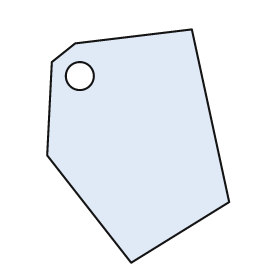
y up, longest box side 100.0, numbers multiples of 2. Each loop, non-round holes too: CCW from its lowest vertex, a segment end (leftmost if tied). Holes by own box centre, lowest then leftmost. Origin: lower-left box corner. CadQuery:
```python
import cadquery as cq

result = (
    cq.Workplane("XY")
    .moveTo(36.0, 0.0)
    .lineTo(78.0, 26.0)
    .lineTo(62.0, 100.0)
    .lineTo(12.0, 94.0)
    .lineTo(2.0, 86.0)
    .lineTo(0.0, 46.0)
    .close()
    .moveTo(14.0, 80.0)
    .circle(6.0)
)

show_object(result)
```